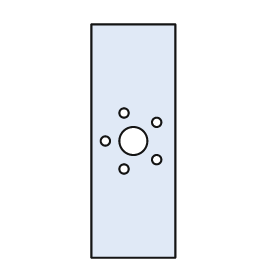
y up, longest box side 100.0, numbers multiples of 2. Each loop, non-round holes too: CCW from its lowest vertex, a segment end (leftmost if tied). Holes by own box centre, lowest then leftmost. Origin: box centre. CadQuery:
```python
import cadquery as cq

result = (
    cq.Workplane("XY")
    .moveTo(-18.0, -50.0)
    .lineTo(18.0, -50.0)
    .lineTo(18.0, 50.0)
    .lineTo(-18.0, 50.0)
    .close()
    .moveTo(-4.0, -12.0)
    .circle(2.0)
    .moveTo(10.0, -8.0)
    .circle(2.0)
    .moveTo(-12.0, 0.0)
    .circle(2.0)
    .moveTo(0.0, 0.0)
    .circle(6.0)
    .moveTo(10.0, 8.0)
    .circle(2.0)
    .moveTo(-4.0, 12.0)
    .circle(2.0)
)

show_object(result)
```